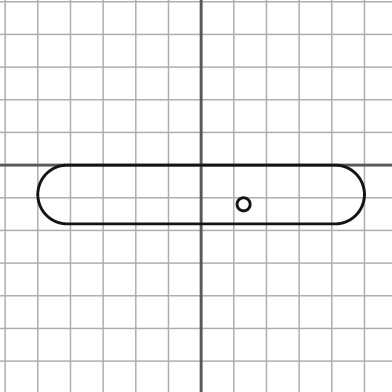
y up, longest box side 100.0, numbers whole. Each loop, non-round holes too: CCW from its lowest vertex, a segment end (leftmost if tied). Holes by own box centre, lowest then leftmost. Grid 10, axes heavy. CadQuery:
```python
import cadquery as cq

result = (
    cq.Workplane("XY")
    .moveTo(-41.0, -18.0)
    .lineTo(41.0, -18.0)
    .threePointArc((50.0, -9.0), (41.0, 0.0))
    .lineTo(-41.0, 0.0)
    .threePointArc((-50.0, -9.0), (-41.0, -18.0))
    .close()
    .moveTo(13.0, -12.0)
    .circle(2.0)
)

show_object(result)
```